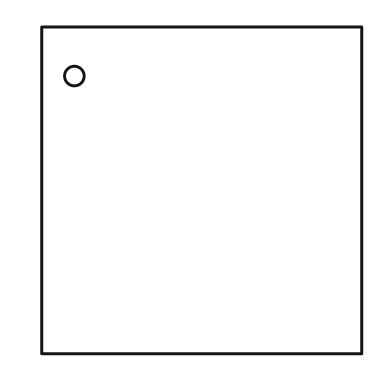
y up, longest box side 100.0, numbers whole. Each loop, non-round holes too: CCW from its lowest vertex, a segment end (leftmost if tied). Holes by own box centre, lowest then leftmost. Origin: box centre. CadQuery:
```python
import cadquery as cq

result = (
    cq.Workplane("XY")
    .moveTo(-49.0, -50.0)
    .lineTo(49.0, -50.0)
    .lineTo(49.0, 50.0)
    .lineTo(-49.0, 50.0)
    .close()
    .moveTo(-39.0, 35.0)
    .circle(3.0)
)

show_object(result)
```